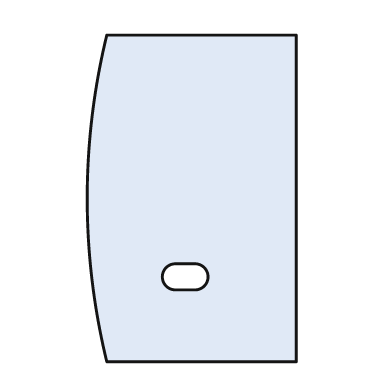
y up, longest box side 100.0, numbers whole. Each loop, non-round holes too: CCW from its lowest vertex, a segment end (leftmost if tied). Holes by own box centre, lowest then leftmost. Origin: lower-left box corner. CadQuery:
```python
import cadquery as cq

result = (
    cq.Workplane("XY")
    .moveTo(6.0, 0.0)
    .lineTo(64.0, 0.0)
    .lineTo(64.0, 100.0)
    .lineTo(6.0, 100.0)
    .threePointArc((0.0, 50.0), (6.0, 0.0))
    .close()
    .moveTo(27.0, 22.0)
    .lineTo(33.0, 22.0)
    .threePointArc((37.0, 26.0), (33.0, 30.0))
    .lineTo(27.0, 30.0)
    .threePointArc((23.0, 26.0), (27.0, 22.0))
    .close()
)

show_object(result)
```